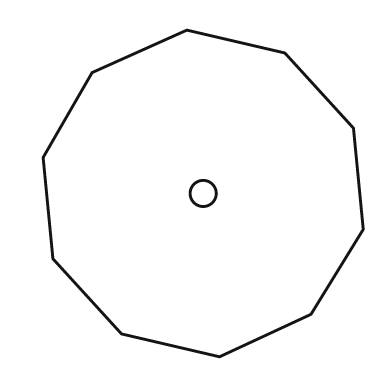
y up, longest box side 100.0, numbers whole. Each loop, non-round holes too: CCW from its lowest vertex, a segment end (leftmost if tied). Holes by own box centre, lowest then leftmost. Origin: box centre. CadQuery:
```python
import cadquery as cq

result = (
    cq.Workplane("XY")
    .moveTo(5.0, -50.0)
    .lineTo(33.0, -37.0)
    .lineTo(49.0, -11.0)
    .lineTo(46.0, 20.0)
    .lineTo(25.0, 43.0)
    .lineTo(-5.0, 50.0)
    .lineTo(-34.0, 37.0)
    .lineTo(-49.0, 11.0)
    .lineTo(-46.0, -20.0)
    .lineTo(-25.0, -43.0)
    .close()
    .moveTo(0.0, 0.0)
    .circle(4.0)
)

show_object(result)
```